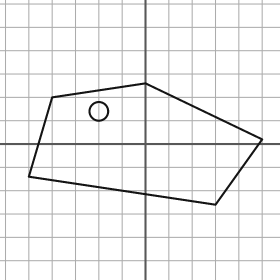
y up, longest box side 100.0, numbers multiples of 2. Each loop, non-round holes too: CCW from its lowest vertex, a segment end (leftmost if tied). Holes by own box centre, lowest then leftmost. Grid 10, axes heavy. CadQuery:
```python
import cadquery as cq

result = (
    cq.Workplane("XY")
    .moveTo(30.0, -26.0)
    .lineTo(50.0, 2.0)
    .lineTo(0.0, 26.0)
    .lineTo(-40.0, 20.0)
    .lineTo(-50.0, -14.0)
    .close()
    .moveTo(-20.0, 14.0)
    .circle(4.0)
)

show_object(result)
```